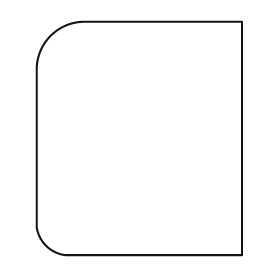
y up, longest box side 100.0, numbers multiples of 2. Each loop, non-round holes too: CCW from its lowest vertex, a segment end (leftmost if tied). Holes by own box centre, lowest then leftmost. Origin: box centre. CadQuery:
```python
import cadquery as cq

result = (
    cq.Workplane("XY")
    .moveTo(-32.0, -50.0)
    .lineTo(44.0, -50.0)
    .lineTo(44.0, 50.0)
    .lineTo(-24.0, 50.0)
    .threePointArc((-38.0, 44.0), (-44.0, 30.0))
    .lineTo(-44.0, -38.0)
    .threePointArc((-40.0, -46.0), (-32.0, -50.0))
    .close()
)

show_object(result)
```